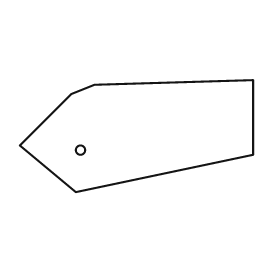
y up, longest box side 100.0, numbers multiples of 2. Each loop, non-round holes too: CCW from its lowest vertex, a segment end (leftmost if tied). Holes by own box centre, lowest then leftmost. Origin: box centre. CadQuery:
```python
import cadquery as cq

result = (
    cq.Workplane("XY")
    .moveTo(-26.0, -24.0)
    .lineTo(50.0, -8.0)
    .lineTo(50.0, 24.0)
    .lineTo(-18.0, 22.0)
    .lineTo(-28.0, 18.0)
    .lineTo(-50.0, -4.0)
    .close()
    .moveTo(-24.0, -6.0)
    .circle(2.0)
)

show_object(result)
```